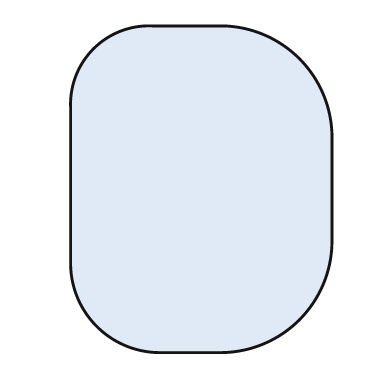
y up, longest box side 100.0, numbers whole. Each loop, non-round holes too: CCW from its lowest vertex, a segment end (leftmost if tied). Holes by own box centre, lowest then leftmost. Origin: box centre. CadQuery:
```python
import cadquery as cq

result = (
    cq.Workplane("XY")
    .moveTo(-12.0, -50.0)
    .lineTo(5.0, -50.0)
    .threePointArc((30.0, -40.0), (40.0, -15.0))
    .lineTo(40.0, 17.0)
    .threePointArc((30.0, 40.0), (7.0, 50.0))
    .lineTo(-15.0, 50.0)
    .threePointArc((-33.0, 43.0), (-40.0, 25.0))
    .lineTo(-40.0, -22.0)
    .threePointArc((-32.0, -42.0), (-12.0, -50.0))
    .close()
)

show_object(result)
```